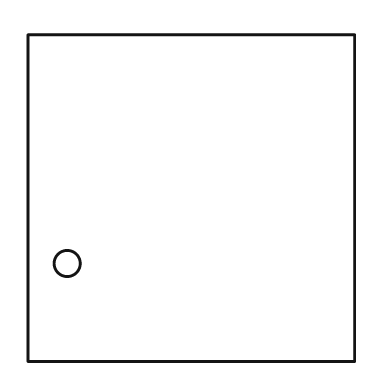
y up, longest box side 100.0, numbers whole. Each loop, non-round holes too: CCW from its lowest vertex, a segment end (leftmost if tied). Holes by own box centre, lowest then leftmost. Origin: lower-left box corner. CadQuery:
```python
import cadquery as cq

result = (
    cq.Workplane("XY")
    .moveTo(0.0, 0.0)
    .lineTo(100.0, 0.0)
    .lineTo(100.0, 100.0)
    .lineTo(0.0, 100.0)
    .close()
    .moveTo(12.0, 30.0)
    .circle(4.0)
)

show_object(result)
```